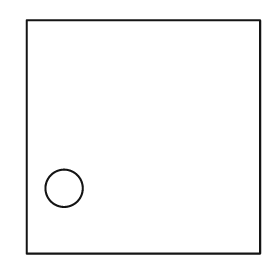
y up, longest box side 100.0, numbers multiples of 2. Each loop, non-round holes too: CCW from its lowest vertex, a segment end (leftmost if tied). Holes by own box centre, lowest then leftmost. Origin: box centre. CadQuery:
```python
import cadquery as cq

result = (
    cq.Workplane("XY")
    .moveTo(-50.0, -50.0)
    .lineTo(50.0, -50.0)
    .lineTo(50.0, 50.0)
    .lineTo(-50.0, 50.0)
    .close()
    .moveTo(-34.0, -22.0)
    .circle(8.0)
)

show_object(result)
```